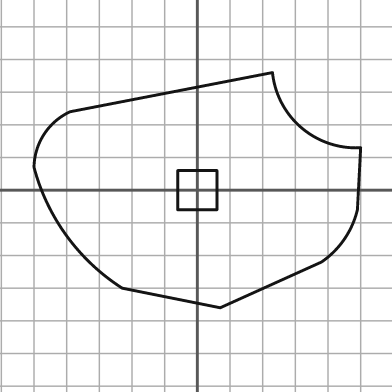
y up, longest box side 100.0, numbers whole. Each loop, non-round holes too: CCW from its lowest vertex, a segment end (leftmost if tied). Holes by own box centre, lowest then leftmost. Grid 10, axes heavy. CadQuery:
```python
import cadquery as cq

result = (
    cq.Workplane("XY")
    .moveTo(7.0, -36.0)
    .lineTo(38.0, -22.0)
    .threePointArc((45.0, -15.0), (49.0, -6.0))
    .lineTo(50.0, 13.0)
    .threePointArc((32.0, 19.0), (23.0, 36.0))
    .lineTo(-39.0, 24.0)
    .threePointArc((-47.0, 17.0), (-50.0, 7.0))
    .threePointArc((-40.0, -14.0), (-23.0, -30.0))
    .close()
    .moveTo(-6.0, -6.0)
    .lineTo(6.0, -6.0)
    .lineTo(6.0, 6.0)
    .lineTo(-6.0, 6.0)
    .close()
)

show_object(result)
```